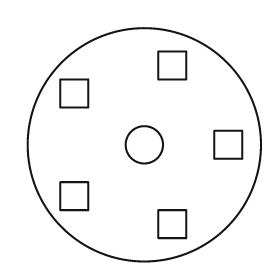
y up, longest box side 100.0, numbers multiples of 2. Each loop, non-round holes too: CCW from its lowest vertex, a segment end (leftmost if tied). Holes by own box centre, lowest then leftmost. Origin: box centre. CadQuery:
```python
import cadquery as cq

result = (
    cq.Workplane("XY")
    .moveTo(0.0, 0.0)
    .circle(50.0)
    .moveTo(6.0, -40.0)
    .lineTo(18.0, -40.0)
    .lineTo(18.0, -28.0)
    .lineTo(6.0, -28.0)
    .close()
    .moveTo(-36.0, -28.0)
    .lineTo(-24.0, -28.0)
    .lineTo(-24.0, -16.0)
    .lineTo(-36.0, -16.0)
    .close()
    .moveTo(0.0, 0.0)
    .circle(8.0)
    .moveTo(30.0, -6.0)
    .lineTo(42.0, -6.0)
    .lineTo(42.0, 6.0)
    .lineTo(30.0, 6.0)
    .close()
    .moveTo(-36.0, 16.0)
    .lineTo(-24.0, 16.0)
    .lineTo(-24.0, 28.0)
    .lineTo(-36.0, 28.0)
    .close()
    .moveTo(6.0, 28.0)
    .lineTo(18.0, 28.0)
    .lineTo(18.0, 40.0)
    .lineTo(6.0, 40.0)
    .close()
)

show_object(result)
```